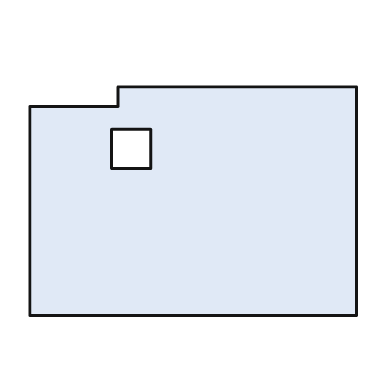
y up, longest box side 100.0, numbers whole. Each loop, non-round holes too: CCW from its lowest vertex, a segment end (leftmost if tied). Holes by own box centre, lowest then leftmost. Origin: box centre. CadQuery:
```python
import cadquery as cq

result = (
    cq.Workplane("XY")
    .moveTo(-50.0, -35.0)
    .lineTo(50.0, -35.0)
    .lineTo(50.0, 35.0)
    .lineTo(-23.0, 35.0)
    .lineTo(-23.0, 29.0)
    .lineTo(-50.0, 29.0)
    .close()
    .moveTo(-25.0, 10.0)
    .lineTo(-13.0, 10.0)
    .lineTo(-13.0, 22.0)
    .lineTo(-25.0, 22.0)
    .close()
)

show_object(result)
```